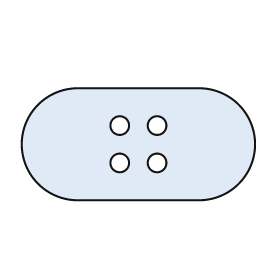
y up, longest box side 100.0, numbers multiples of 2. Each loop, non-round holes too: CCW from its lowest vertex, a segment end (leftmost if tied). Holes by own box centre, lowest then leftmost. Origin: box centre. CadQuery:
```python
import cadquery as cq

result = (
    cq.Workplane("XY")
    .moveTo(-26.0, -24.0)
    .lineTo(26.0, -24.0)
    .threePointArc((50.0, 0.0), (26.0, 24.0))
    .lineTo(-26.0, 24.0)
    .threePointArc((-50.0, 0.0), (-26.0, -24.0))
    .close()
    .moveTo(-8.0, -8.0)
    .circle(4.0)
    .moveTo(8.0, -8.0)
    .circle(4.0)
    .moveTo(-8.0, 8.0)
    .circle(4.0)
    .moveTo(8.0, 8.0)
    .circle(4.0)
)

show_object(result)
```